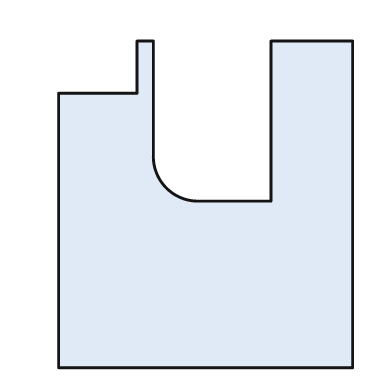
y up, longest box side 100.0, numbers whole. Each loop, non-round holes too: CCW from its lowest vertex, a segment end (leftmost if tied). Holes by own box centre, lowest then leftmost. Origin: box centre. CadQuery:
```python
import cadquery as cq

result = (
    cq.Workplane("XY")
    .moveTo(-45.0, -50.0)
    .lineTo(45.0, -50.0)
    .lineTo(45.0, 50.0)
    .lineTo(20.0, 50.0)
    .lineTo(20.0, 1.0)
    .lineTo(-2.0, 1.0)
    .threePointArc((-12.0, 5.0), (-16.0, 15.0))
    .lineTo(-16.0, 50.0)
    .lineTo(-21.0, 50.0)
    .lineTo(-21.0, 34.0)
    .lineTo(-45.0, 34.0)
    .close()
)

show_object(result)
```